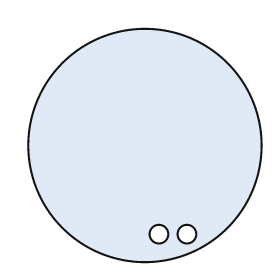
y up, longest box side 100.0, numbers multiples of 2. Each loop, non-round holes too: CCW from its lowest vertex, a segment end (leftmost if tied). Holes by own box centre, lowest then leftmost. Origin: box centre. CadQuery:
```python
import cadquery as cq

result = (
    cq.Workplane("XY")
    .moveTo(0.0, 0.0)
    .circle(50.0)
    .moveTo(6.0, -38.0)
    .circle(4.0)
    .moveTo(18.0, -38.0)
    .circle(4.0)
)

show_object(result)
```